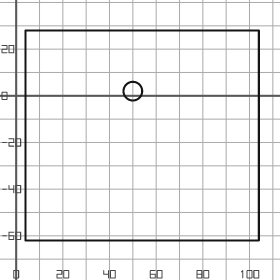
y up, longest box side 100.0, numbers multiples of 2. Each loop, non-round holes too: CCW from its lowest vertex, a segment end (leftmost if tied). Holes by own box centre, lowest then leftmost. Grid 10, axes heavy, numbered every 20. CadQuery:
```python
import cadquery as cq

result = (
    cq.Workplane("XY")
    .moveTo(4.0, -62.0)
    .lineTo(104.0, -62.0)
    .lineTo(104.0, 28.0)
    .lineTo(4.0, 28.0)
    .close()
    .moveTo(50.0, 2.0)
    .circle(4.0)
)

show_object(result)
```